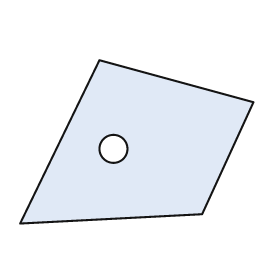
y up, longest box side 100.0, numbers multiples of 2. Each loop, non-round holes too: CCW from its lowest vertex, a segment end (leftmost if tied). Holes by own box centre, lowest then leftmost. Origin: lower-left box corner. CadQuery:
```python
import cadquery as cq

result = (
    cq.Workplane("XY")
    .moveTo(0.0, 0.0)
    .lineTo(78.0, 4.0)
    .lineTo(100.0, 52.0)
    .lineTo(34.0, 70.0)
    .close()
    .moveTo(40.0, 32.0)
    .circle(6.0)
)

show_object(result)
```